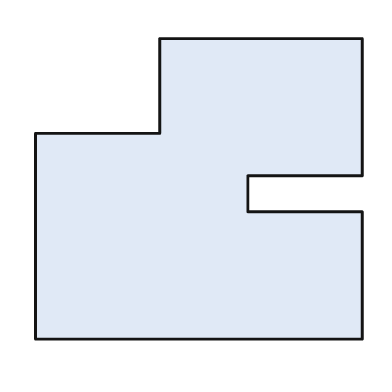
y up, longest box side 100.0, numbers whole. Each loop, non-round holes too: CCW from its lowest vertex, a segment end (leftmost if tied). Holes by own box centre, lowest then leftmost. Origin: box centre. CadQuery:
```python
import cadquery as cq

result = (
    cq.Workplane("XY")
    .moveTo(-50.0, -46.0)
    .lineTo(50.0, -46.0)
    .lineTo(50.0, -7.0)
    .lineTo(15.0, -7.0)
    .lineTo(15.0, 4.0)
    .lineTo(50.0, 4.0)
    .lineTo(50.0, 46.0)
    .lineTo(-12.0, 46.0)
    .lineTo(-12.0, 17.0)
    .lineTo(-50.0, 17.0)
    .close()
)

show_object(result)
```